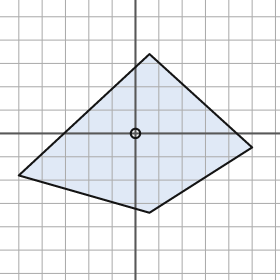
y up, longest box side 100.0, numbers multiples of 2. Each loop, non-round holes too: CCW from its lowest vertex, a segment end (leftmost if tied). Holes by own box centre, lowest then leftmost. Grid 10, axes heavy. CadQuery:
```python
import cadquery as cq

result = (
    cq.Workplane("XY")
    .moveTo(6.0, -34.0)
    .lineTo(50.0, -6.0)
    .lineTo(6.0, 34.0)
    .lineTo(-50.0, -18.0)
    .close()
    .moveTo(0.0, 0.0)
    .circle(2.0)
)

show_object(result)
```